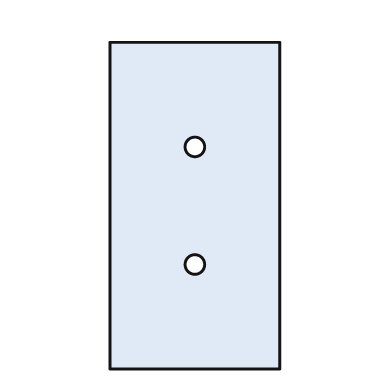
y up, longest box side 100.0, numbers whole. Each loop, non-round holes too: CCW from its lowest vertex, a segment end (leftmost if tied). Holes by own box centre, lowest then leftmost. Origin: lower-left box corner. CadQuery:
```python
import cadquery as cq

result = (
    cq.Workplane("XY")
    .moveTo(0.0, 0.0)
    .lineTo(52.0, 0.0)
    .lineTo(52.0, 100.0)
    .lineTo(0.0, 100.0)
    .close()
    .moveTo(26.0, 32.0)
    .circle(3.0)
    .moveTo(26.0, 68.0)
    .circle(3.0)
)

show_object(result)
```